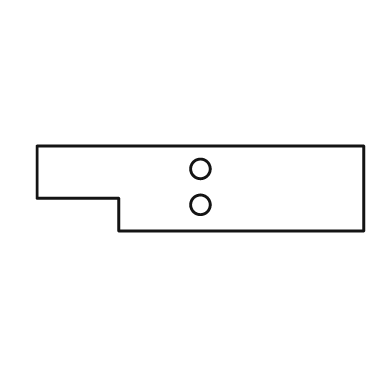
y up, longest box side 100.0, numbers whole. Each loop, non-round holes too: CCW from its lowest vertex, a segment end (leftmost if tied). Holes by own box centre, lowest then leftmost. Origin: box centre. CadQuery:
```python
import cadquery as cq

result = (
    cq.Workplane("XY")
    .moveTo(-25.0, -13.0)
    .lineTo(50.0, -13.0)
    .lineTo(50.0, 13.0)
    .lineTo(-50.0, 13.0)
    .lineTo(-50.0, -3.0)
    .lineTo(-25.0, -3.0)
    .close()
    .moveTo(0.0, -5.0)
    .circle(3.0)
    .moveTo(0.0, 6.0)
    .circle(3.0)
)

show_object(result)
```